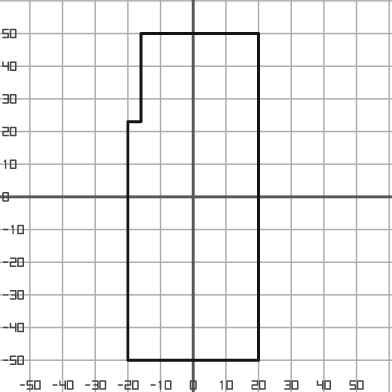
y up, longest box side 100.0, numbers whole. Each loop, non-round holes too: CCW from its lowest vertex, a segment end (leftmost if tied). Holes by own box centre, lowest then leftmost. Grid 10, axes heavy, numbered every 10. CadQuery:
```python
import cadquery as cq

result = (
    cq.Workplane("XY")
    .moveTo(-20.0, -50.0)
    .lineTo(20.0, -50.0)
    .lineTo(20.0, 50.0)
    .lineTo(-16.0, 50.0)
    .lineTo(-16.0, 23.0)
    .lineTo(-20.0, 23.0)
    .close()
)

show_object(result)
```